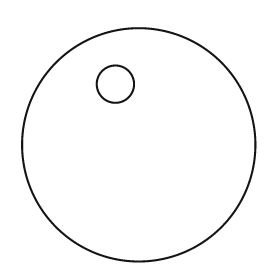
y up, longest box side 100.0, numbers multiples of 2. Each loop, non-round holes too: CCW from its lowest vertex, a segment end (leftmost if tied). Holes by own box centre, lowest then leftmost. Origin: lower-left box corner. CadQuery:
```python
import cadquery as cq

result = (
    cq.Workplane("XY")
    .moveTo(50.0, 50.0)
    .circle(50.0)
    .moveTo(40.0, 76.0)
    .circle(8.0)
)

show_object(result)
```